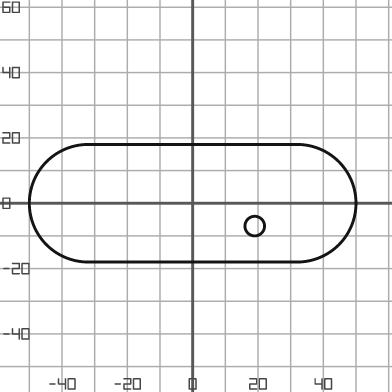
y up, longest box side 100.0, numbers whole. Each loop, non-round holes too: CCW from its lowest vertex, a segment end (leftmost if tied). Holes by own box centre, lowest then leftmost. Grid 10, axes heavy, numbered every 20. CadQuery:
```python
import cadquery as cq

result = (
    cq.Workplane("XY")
    .moveTo(-32.0, -18.0)
    .lineTo(32.0, -18.0)
    .threePointArc((50.0, 0.0), (32.0, 18.0))
    .lineTo(-32.0, 18.0)
    .threePointArc((-50.0, 0.0), (-32.0, -18.0))
    .close()
    .moveTo(19.0, -7.0)
    .circle(3.0)
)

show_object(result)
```